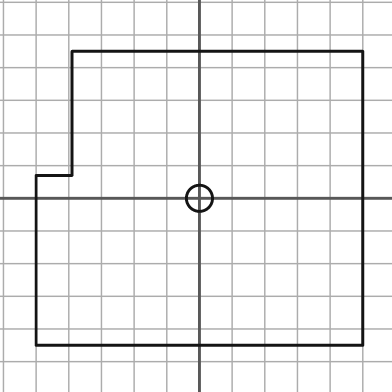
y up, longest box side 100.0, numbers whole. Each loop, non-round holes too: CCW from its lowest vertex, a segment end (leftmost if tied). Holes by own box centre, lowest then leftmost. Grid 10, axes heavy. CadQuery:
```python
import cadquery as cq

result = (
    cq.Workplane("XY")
    .moveTo(-50.0, -45.0)
    .lineTo(50.0, -45.0)
    .lineTo(50.0, 45.0)
    .lineTo(-39.0, 45.0)
    .lineTo(-39.0, 7.0)
    .lineTo(-50.0, 7.0)
    .close()
    .moveTo(0.0, 0.0)
    .circle(4.0)
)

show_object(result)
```